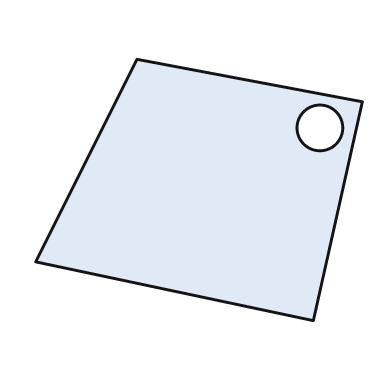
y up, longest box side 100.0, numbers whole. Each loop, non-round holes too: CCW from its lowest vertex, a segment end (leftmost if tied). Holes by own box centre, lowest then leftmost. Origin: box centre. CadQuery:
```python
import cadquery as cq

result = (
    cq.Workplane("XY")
    .moveTo(35.0, -40.0)
    .lineTo(50.0, 27.0)
    .lineTo(-19.0, 40.0)
    .lineTo(-50.0, -22.0)
    .close()
    .moveTo(37.0, 19.0)
    .circle(7.0)
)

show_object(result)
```